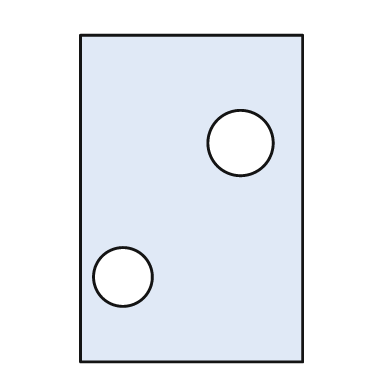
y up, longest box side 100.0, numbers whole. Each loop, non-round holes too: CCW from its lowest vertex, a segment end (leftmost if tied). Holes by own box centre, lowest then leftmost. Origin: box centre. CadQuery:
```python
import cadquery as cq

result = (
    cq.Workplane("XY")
    .moveTo(-34.0, -50.0)
    .lineTo(34.0, -50.0)
    .lineTo(34.0, 50.0)
    .lineTo(-34.0, 50.0)
    .close()
    .moveTo(-21.0, -24.0)
    .circle(9.0)
    .moveTo(15.0, 17.0)
    .circle(10.0)
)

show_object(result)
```